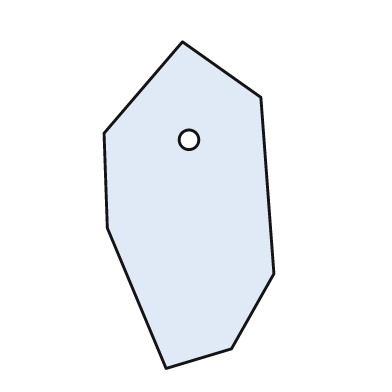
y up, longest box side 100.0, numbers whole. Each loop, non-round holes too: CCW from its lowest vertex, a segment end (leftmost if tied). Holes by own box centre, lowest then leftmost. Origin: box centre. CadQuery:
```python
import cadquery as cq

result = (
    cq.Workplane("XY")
    .moveTo(-7.0, -50.0)
    .lineTo(13.0, -44.0)
    .lineTo(26.0, -21.0)
    .lineTo(22.0, 33.0)
    .lineTo(-2.0, 50.0)
    .lineTo(-26.0, 22.0)
    .lineTo(-25.0, -7.0)
    .close()
    .moveTo(0.0, 20.0)
    .circle(3.0)
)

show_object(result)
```